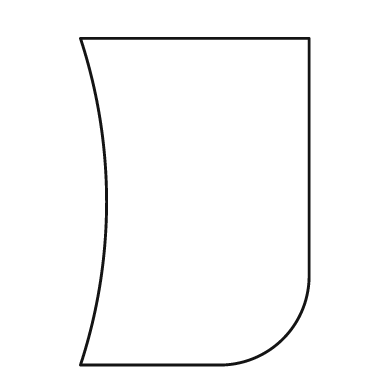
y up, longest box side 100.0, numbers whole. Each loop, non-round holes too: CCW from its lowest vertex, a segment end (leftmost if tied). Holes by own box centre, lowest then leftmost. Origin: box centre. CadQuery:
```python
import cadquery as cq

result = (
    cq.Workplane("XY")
    .moveTo(-35.0, -50.0)
    .lineTo(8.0, -50.0)
    .threePointArc((27.0, -42.0), (35.0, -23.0))
    .lineTo(35.0, 50.0)
    .lineTo(-35.0, 50.0)
    .threePointArc((-27.0, 0.0), (-35.0, -50.0))
    .close()
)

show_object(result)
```